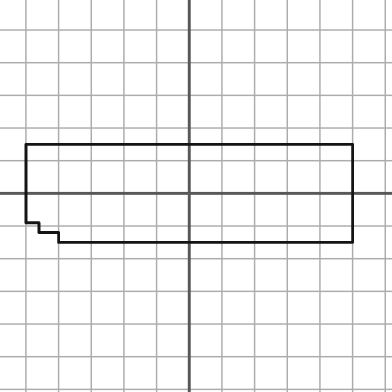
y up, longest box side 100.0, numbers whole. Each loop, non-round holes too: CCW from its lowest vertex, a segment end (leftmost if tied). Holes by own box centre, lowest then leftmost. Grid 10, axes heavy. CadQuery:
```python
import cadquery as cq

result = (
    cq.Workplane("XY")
    .moveTo(-40.0, -15.0)
    .lineTo(50.0, -15.0)
    .lineTo(50.0, 15.0)
    .lineTo(-50.0, 15.0)
    .lineTo(-50.0, -9.0)
    .lineTo(-46.0, -9.0)
    .lineTo(-46.0, -12.0)
    .lineTo(-40.0, -12.0)
    .close()
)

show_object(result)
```